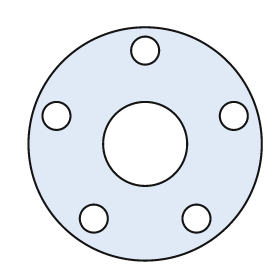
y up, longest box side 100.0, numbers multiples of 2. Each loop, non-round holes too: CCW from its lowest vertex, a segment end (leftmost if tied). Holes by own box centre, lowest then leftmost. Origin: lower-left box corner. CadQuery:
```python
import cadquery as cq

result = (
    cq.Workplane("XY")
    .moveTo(50.0, 50.0)
    .circle(50.0)
    .moveTo(28.0, 18.0)
    .circle(6.0)
    .moveTo(72.0, 18.0)
    .circle(6.0)
    .moveTo(50.0, 50.0)
    .circle(18.0)
    .moveTo(12.0, 62.0)
    .circle(6.0)
    .moveTo(88.0, 62.0)
    .circle(6.0)
    .moveTo(50.0, 90.0)
    .circle(6.0)
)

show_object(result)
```